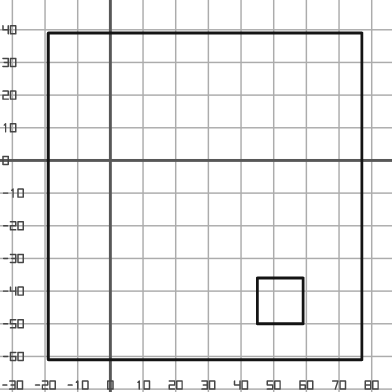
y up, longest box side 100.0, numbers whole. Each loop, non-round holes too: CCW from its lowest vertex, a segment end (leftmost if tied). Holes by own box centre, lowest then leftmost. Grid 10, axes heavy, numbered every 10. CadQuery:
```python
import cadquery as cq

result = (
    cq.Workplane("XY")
    .moveTo(-19.0, -61.0)
    .lineTo(77.0, -61.0)
    .lineTo(77.0, 39.0)
    .lineTo(-19.0, 39.0)
    .close()
    .moveTo(45.0, -50.0)
    .lineTo(59.0, -50.0)
    .lineTo(59.0, -36.0)
    .lineTo(45.0, -36.0)
    .close()
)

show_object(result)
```